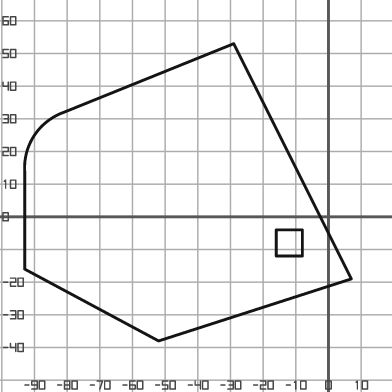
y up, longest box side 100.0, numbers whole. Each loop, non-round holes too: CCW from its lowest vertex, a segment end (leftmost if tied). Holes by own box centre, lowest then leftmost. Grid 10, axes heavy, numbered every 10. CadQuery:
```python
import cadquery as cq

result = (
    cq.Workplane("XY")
    .moveTo(-52.0, -38.0)
    .lineTo(7.0, -19.0)
    .lineTo(-29.0, 53.0)
    .lineTo(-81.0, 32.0)
    .threePointArc((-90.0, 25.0), (-93.0, 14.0))
    .lineTo(-93.0, -16.0)
    .close()
    .moveTo(-16.0, -12.0)
    .lineTo(-8.0, -12.0)
    .lineTo(-8.0, -4.0)
    .lineTo(-16.0, -4.0)
    .close()
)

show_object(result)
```